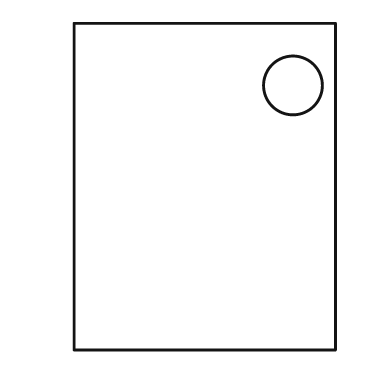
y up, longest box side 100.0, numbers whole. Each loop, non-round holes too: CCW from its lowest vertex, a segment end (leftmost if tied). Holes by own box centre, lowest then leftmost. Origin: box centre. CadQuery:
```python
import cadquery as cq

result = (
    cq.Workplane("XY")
    .moveTo(-40.0, -50.0)
    .lineTo(40.0, -50.0)
    .lineTo(40.0, 50.0)
    .lineTo(-40.0, 50.0)
    .close()
    .moveTo(27.0, 31.0)
    .circle(9.0)
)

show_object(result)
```